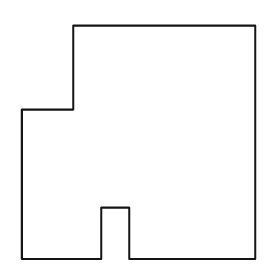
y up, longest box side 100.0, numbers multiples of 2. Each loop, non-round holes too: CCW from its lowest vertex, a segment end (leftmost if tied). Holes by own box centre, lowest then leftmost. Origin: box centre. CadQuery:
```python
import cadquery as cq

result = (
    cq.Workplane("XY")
    .moveTo(-50.0, -50.0)
    .lineTo(-16.0, -50.0)
    .lineTo(-16.0, -28.0)
    .lineTo(-4.0, -28.0)
    .lineTo(-4.0, -50.0)
    .lineTo(50.0, -50.0)
    .lineTo(50.0, 50.0)
    .lineTo(-28.0, 50.0)
    .lineTo(-28.0, 14.0)
    .lineTo(-50.0, 14.0)
    .close()
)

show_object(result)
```